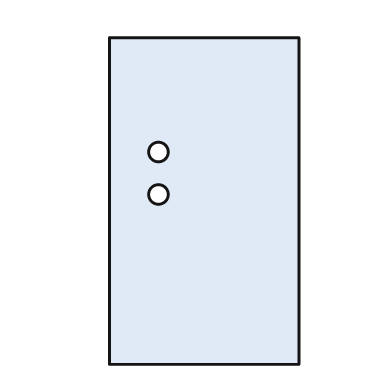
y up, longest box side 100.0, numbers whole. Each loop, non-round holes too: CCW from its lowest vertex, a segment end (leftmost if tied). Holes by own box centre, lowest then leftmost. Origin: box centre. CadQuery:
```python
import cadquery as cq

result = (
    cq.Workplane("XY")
    .moveTo(-29.0, -50.0)
    .lineTo(29.0, -50.0)
    .lineTo(29.0, 50.0)
    .lineTo(-29.0, 50.0)
    .close()
    .moveTo(-14.0, 2.0)
    .circle(3.0)
    .moveTo(-14.0, 15.0)
    .circle(3.0)
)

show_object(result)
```